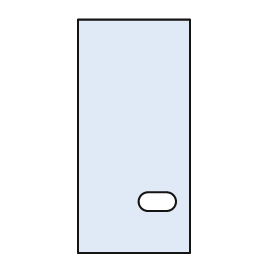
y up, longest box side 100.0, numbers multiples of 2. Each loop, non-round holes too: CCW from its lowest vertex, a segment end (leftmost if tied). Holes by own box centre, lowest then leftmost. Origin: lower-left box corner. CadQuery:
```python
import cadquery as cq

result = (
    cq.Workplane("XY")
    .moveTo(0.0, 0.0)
    .lineTo(48.0, 0.0)
    .lineTo(48.0, 100.0)
    .lineTo(0.0, 100.0)
    .close()
    .moveTo(30.0, 18.0)
    .lineTo(38.0, 18.0)
    .threePointArc((42.0, 22.0), (38.0, 26.0))
    .lineTo(30.0, 26.0)
    .threePointArc((26.0, 22.0), (30.0, 18.0))
    .close()
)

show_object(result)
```